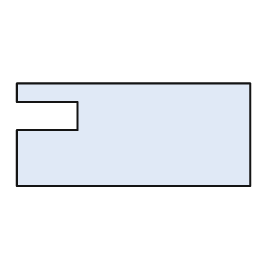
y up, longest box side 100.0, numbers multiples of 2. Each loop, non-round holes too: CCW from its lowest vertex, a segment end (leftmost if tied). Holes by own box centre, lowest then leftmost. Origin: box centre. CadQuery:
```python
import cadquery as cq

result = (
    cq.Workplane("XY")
    .moveTo(-50.0, -22.0)
    .lineTo(50.0, -22.0)
    .lineTo(50.0, 22.0)
    .lineTo(-50.0, 22.0)
    .lineTo(-50.0, 14.0)
    .lineTo(-24.0, 14.0)
    .lineTo(-24.0, 2.0)
    .lineTo(-50.0, 2.0)
    .close()
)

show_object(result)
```